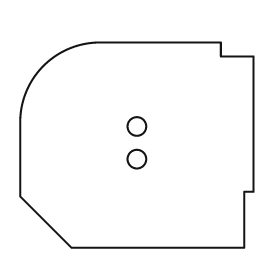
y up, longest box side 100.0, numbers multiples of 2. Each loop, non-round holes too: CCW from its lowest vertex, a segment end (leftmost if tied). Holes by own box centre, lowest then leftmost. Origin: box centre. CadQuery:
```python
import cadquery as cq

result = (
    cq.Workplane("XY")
    .moveTo(-28.0, -44.0)
    .lineTo(46.0, -44.0)
    .lineTo(46.0, -20.0)
    .lineTo(50.0, -20.0)
    .lineTo(50.0, 38.0)
    .lineTo(36.0, 38.0)
    .lineTo(36.0, 44.0)
    .lineTo(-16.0, 44.0)
    .threePointArc((-40.0, 34.0), (-50.0, 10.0))
    .lineTo(-50.0, -22.0)
    .close()
    .moveTo(0.0, -6.0)
    .circle(4.0)
    .moveTo(0.0, 8.0)
    .circle(4.0)
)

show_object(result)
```